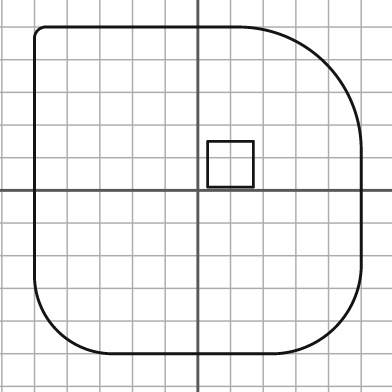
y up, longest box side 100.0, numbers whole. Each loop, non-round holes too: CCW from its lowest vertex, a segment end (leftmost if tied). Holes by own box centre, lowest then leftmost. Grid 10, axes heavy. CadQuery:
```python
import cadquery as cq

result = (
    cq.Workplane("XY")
    .moveTo(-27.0, -50.0)
    .lineTo(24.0, -50.0)
    .threePointArc((42.0, -42.0), (50.0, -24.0))
    .lineTo(50.0, 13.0)
    .threePointArc((39.0, 39.0), (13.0, 50.0))
    .lineTo(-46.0, 50.0)
    .threePointArc((-49.0, 49.0), (-50.0, 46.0))
    .lineTo(-50.0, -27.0)
    .threePointArc((-43.0, -43.0), (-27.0, -50.0))
    .close()
    .moveTo(3.0, 1.0)
    .lineTo(17.0, 1.0)
    .lineTo(17.0, 15.0)
    .lineTo(3.0, 15.0)
    .close()
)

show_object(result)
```